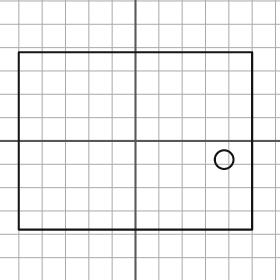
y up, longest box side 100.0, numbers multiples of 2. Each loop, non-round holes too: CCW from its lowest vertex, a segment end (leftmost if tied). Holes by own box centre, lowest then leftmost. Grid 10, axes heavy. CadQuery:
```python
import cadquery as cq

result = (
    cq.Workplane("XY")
    .moveTo(-50.0, -38.0)
    .lineTo(50.0, -38.0)
    .lineTo(50.0, 38.0)
    .lineTo(-50.0, 38.0)
    .close()
    .moveTo(38.0, -8.0)
    .circle(4.0)
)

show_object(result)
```